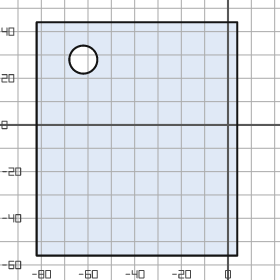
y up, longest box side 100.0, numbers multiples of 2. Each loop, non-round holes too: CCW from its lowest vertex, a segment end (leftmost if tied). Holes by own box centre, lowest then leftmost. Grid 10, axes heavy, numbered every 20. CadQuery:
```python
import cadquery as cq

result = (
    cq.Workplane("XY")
    .moveTo(-82.0, -56.0)
    .lineTo(4.0, -56.0)
    .lineTo(4.0, 44.0)
    .lineTo(-82.0, 44.0)
    .close()
    .moveTo(-62.0, 28.0)
    .circle(6.0)
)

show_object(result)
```